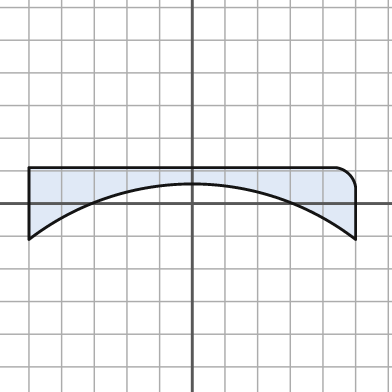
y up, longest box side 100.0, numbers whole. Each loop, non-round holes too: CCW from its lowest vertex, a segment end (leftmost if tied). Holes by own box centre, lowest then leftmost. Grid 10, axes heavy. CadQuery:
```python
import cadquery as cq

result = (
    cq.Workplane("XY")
    .moveTo(-50.0, -11.0)
    .threePointArc((0.0, 6.0), (50.0, -11.0))
    .lineTo(50.0, 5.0)
    .threePointArc((48.0, 9.0), (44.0, 11.0))
    .lineTo(-50.0, 11.0)
    .close()
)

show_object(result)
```